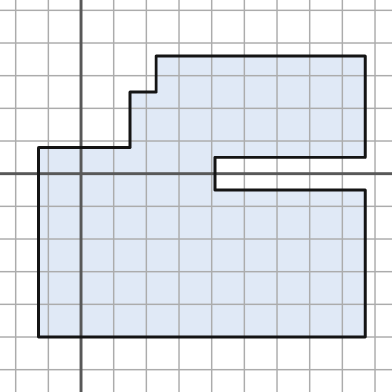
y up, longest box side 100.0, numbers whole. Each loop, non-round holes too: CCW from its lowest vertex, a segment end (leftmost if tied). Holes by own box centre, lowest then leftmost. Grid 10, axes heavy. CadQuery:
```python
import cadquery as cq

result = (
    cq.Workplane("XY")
    .moveTo(-13.0, -50.0)
    .lineTo(87.0, -50.0)
    .lineTo(87.0, -5.0)
    .lineTo(41.0, -5.0)
    .lineTo(41.0, 5.0)
    .lineTo(87.0, 5.0)
    .lineTo(87.0, 36.0)
    .lineTo(23.0, 36.0)
    .lineTo(23.0, 25.0)
    .lineTo(15.0, 25.0)
    .lineTo(15.0, 8.0)
    .lineTo(-13.0, 8.0)
    .close()
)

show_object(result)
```